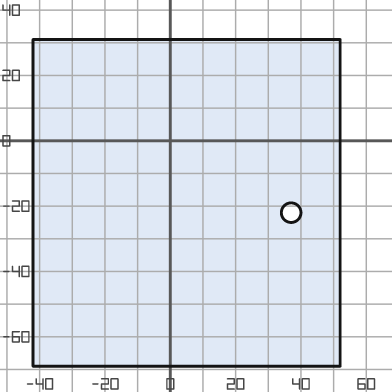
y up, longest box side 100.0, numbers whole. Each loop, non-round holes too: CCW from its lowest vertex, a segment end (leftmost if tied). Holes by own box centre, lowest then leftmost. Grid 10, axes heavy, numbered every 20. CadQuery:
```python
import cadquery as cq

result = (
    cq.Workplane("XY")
    .moveTo(-42.0, -69.0)
    .lineTo(52.0, -69.0)
    .lineTo(52.0, 31.0)
    .lineTo(-42.0, 31.0)
    .close()
    .moveTo(37.0, -22.0)
    .circle(3.0)
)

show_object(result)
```